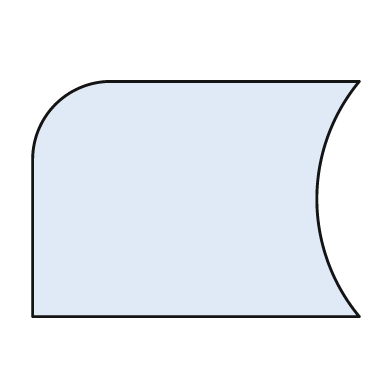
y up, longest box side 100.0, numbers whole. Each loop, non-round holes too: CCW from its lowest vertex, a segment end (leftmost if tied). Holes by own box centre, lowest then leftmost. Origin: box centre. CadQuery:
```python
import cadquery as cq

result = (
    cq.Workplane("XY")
    .moveTo(-50.0, -36.0)
    .lineTo(50.0, -36.0)
    .threePointArc((37.0, 0.0), (50.0, 36.0))
    .lineTo(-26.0, 36.0)
    .threePointArc((-43.0, 29.0), (-50.0, 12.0))
    .close()
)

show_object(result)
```